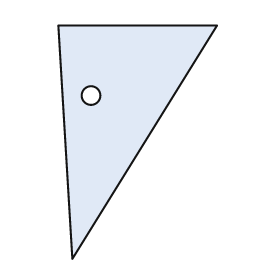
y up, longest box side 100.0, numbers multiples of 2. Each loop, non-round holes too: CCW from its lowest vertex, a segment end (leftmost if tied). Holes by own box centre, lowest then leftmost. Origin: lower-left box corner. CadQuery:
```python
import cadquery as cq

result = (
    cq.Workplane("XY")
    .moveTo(6.0, 0.0)
    .lineTo(68.0, 100.0)
    .lineTo(0.0, 100.0)
    .close()
    .moveTo(14.0, 70.0)
    .circle(4.0)
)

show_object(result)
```